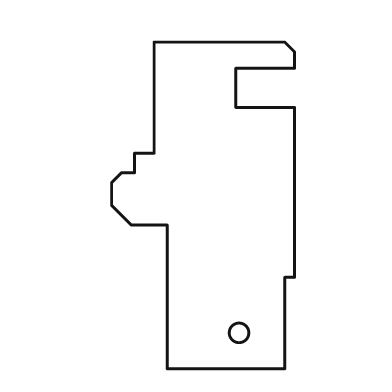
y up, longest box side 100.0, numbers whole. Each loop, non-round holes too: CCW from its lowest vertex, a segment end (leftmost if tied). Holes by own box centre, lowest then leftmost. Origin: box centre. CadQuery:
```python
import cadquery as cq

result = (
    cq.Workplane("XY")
    .moveTo(-11.0, -50.0)
    .lineTo(25.0, -50.0)
    .lineTo(25.0, -22.0)
    .lineTo(28.0, -22.0)
    .lineTo(28.0, 30.0)
    .lineTo(10.0, 30.0)
    .lineTo(10.0, 42.0)
    .lineTo(28.0, 42.0)
    .lineTo(28.0, 47.0)
    .lineTo(25.0, 50.0)
    .lineTo(-15.0, 50.0)
    .lineTo(-15.0, 16.0)
    .lineTo(-21.0, 16.0)
    .lineTo(-21.0, 10.0)
    .lineTo(-25.0, 10.0)
    .lineTo(-28.0, 7.0)
    .lineTo(-28.0, 0.0)
    .lineTo(-22.0, -6.0)
    .lineTo(-11.0, -6.0)
    .close()
    .moveTo(11.0, -39.0)
    .circle(3.0)
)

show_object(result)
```